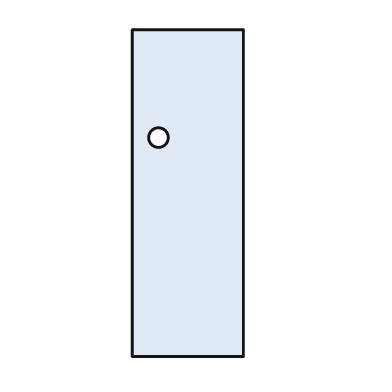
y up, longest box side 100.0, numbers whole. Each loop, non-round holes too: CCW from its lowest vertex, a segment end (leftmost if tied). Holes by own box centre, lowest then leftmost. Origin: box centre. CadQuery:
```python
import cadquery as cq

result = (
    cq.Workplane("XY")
    .moveTo(-17.0, -50.0)
    .lineTo(17.0, -50.0)
    .lineTo(17.0, 50.0)
    .lineTo(-17.0, 50.0)
    .close()
    .moveTo(-9.0, 17.0)
    .circle(3.0)
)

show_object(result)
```